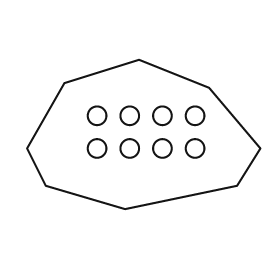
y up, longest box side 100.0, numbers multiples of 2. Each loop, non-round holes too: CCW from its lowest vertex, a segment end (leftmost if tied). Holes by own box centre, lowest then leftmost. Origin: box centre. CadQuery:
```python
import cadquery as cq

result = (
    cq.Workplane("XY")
    .moveTo(-8.0, -32.0)
    .lineTo(40.0, -22.0)
    .lineTo(50.0, -6.0)
    .lineTo(28.0, 20.0)
    .lineTo(-2.0, 32.0)
    .lineTo(-34.0, 22.0)
    .lineTo(-50.0, -6.0)
    .lineTo(-42.0, -22.0)
    .close()
    .moveTo(-20.0, -6.0)
    .circle(4.0)
    .moveTo(-6.0, -6.0)
    .circle(4.0)
    .moveTo(8.0, -6.0)
    .circle(4.0)
    .moveTo(22.0, -6.0)
    .circle(4.0)
    .moveTo(-20.0, 8.0)
    .circle(4.0)
    .moveTo(-6.0, 8.0)
    .circle(4.0)
    .moveTo(8.0, 8.0)
    .circle(4.0)
    .moveTo(22.0, 8.0)
    .circle(4.0)
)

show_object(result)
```